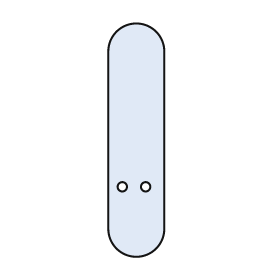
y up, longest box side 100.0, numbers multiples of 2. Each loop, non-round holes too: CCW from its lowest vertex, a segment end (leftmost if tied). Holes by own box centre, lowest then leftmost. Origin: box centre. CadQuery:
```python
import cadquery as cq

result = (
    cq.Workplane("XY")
    .moveTo(-12.0, -38.0)
    .threePointArc((0.0, -50.0), (12.0, -38.0))
    .lineTo(12.0, 38.0)
    .threePointArc((0.0, 50.0), (-12.0, 38.0))
    .close()
    .moveTo(-6.0, -20.0)
    .circle(2.0)
    .moveTo(4.0, -20.0)
    .circle(2.0)
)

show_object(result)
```